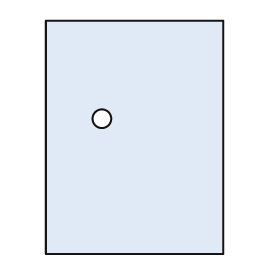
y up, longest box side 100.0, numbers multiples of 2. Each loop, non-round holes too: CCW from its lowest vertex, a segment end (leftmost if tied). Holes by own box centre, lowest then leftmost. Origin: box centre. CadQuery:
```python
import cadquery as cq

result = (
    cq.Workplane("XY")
    .moveTo(-38.0, -50.0)
    .lineTo(38.0, -50.0)
    .lineTo(38.0, 50.0)
    .lineTo(-38.0, 50.0)
    .close()
    .moveTo(-14.0, 8.0)
    .circle(4.0)
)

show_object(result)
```